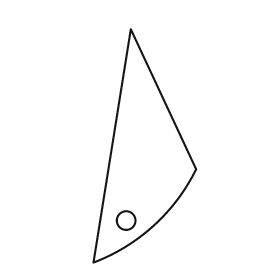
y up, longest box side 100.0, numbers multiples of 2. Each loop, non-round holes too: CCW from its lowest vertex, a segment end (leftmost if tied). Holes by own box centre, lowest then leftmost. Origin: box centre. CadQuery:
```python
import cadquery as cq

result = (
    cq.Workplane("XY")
    .moveTo(-22.0, -50.0)
    .threePointArc((4.0, -34.0), (22.0, -10.0))
    .lineTo(-6.0, 50.0)
    .close()
    .moveTo(-8.0, -32.0)
    .circle(4.0)
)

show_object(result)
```